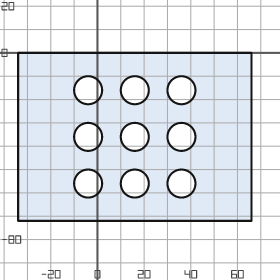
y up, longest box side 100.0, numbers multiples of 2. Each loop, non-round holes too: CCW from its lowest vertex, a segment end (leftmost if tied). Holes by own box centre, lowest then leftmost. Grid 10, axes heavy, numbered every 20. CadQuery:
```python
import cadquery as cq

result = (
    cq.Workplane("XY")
    .moveTo(-34.0, -72.0)
    .lineTo(66.0, -72.0)
    .lineTo(66.0, 0.0)
    .lineTo(-34.0, 0.0)
    .close()
    .moveTo(-4.0, -56.0)
    .circle(6.0)
    .moveTo(16.0, -56.0)
    .circle(6.0)
    .moveTo(36.0, -56.0)
    .circle(6.0)
    .moveTo(-4.0, -36.0)
    .circle(6.0)
    .moveTo(16.0, -36.0)
    .circle(6.0)
    .moveTo(36.0, -36.0)
    .circle(6.0)
    .moveTo(-4.0, -16.0)
    .circle(6.0)
    .moveTo(16.0, -16.0)
    .circle(6.0)
    .moveTo(36.0, -16.0)
    .circle(6.0)
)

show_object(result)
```